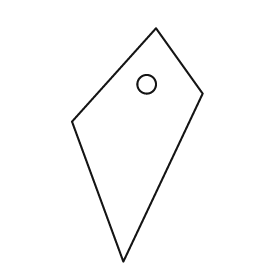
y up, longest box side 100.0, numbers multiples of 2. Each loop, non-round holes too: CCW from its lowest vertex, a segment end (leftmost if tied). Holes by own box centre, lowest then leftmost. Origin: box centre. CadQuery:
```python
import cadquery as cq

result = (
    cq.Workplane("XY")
    .moveTo(-6.0, -50.0)
    .lineTo(28.0, 22.0)
    .lineTo(8.0, 50.0)
    .lineTo(-28.0, 10.0)
    .close()
    .moveTo(4.0, 26.0)
    .circle(4.0)
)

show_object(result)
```